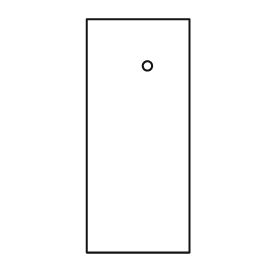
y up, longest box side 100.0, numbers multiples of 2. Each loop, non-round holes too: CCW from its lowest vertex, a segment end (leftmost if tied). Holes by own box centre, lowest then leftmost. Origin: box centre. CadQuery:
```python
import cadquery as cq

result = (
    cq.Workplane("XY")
    .moveTo(-22.0, -50.0)
    .lineTo(22.0, -50.0)
    .lineTo(22.0, 50.0)
    .lineTo(-22.0, 50.0)
    .close()
    .moveTo(4.0, 30.0)
    .circle(2.0)
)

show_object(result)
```